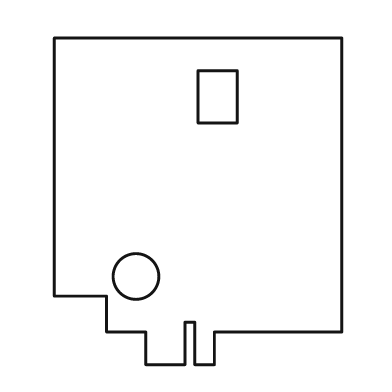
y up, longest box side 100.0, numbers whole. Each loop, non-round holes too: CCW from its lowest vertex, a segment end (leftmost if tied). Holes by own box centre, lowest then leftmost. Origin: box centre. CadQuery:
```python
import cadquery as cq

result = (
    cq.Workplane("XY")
    .moveTo(-16.0, -50.0)
    .lineTo(-4.0, -50.0)
    .lineTo(-4.0, -37.0)
    .lineTo(-1.0, -37.0)
    .lineTo(-1.0, -50.0)
    .lineTo(5.0, -50.0)
    .lineTo(5.0, -40.0)
    .lineTo(44.0, -40.0)
    .lineTo(44.0, 50.0)
    .lineTo(-44.0, 50.0)
    .lineTo(-44.0, -29.0)
    .lineTo(-28.0, -29.0)
    .lineTo(-28.0, -40.0)
    .lineTo(-16.0, -40.0)
    .close()
    .moveTo(-19.0, -23.0)
    .circle(7.0)
    .moveTo(0.0, 24.0)
    .lineTo(12.0, 24.0)
    .lineTo(12.0, 40.0)
    .lineTo(0.0, 40.0)
    .close()
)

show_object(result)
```